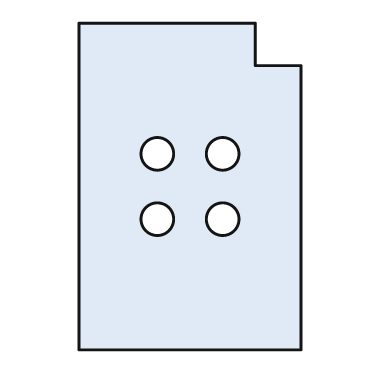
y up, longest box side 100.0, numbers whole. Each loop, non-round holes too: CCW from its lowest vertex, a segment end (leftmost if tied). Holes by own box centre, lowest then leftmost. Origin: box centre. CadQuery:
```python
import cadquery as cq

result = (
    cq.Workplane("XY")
    .moveTo(-34.0, -50.0)
    .lineTo(34.0, -50.0)
    .lineTo(34.0, 37.0)
    .lineTo(20.0, 37.0)
    .lineTo(20.0, 50.0)
    .lineTo(-34.0, 50.0)
    .close()
    .moveTo(-10.0, -10.0)
    .circle(5.0)
    .moveTo(10.0, -10.0)
    .circle(5.0)
    .moveTo(-10.0, 10.0)
    .circle(5.0)
    .moveTo(10.0, 10.0)
    .circle(5.0)
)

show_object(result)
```